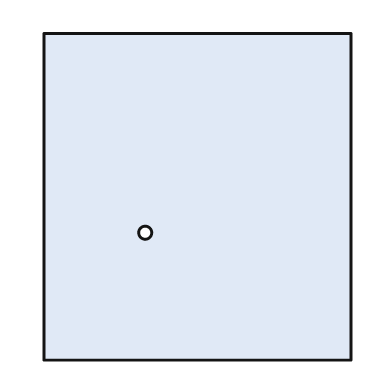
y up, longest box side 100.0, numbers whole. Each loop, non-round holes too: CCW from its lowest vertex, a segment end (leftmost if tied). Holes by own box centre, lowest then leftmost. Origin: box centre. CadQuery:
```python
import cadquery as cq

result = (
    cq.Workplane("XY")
    .moveTo(-47.0, -50.0)
    .lineTo(47.0, -50.0)
    .lineTo(47.0, 50.0)
    .lineTo(-47.0, 50.0)
    .close()
    .moveTo(-16.0, -11.0)
    .circle(2.0)
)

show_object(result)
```